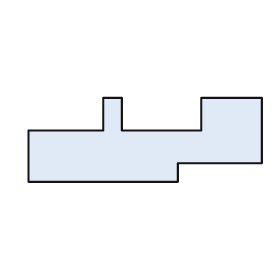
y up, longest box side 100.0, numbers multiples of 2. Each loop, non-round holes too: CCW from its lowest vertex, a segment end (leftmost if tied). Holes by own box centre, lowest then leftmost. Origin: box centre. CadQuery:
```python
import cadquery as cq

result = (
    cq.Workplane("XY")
    .moveTo(-50.0, -18.0)
    .lineTo(14.0, -18.0)
    .lineTo(14.0, -10.0)
    .lineTo(50.0, -10.0)
    .lineTo(50.0, 18.0)
    .lineTo(24.0, 18.0)
    .lineTo(24.0, 4.0)
    .lineTo(-10.0, 4.0)
    .lineTo(-10.0, 18.0)
    .lineTo(-18.0, 18.0)
    .lineTo(-18.0, 4.0)
    .lineTo(-50.0, 4.0)
    .close()
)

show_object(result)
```